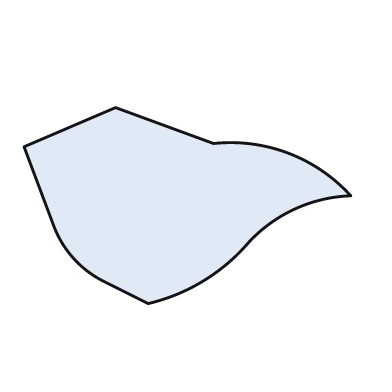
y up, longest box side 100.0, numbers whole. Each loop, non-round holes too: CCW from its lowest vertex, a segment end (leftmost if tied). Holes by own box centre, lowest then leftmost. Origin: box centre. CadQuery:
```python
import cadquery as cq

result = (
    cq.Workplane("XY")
    .moveTo(-12.0, -30.0)
    .threePointArc((5.0, -23.0), (19.0, -11.0))
    .threePointArc((33.0, -1.0), (50.0, 3.0))
    .threePointArc((31.0, 16.0), (8.0, 19.0))
    .lineTo(-22.0, 30.0)
    .lineTo(-50.0, 18.0)
    .lineTo(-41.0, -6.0)
    .threePointArc((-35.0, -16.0), (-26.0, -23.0))
    .close()
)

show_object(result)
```